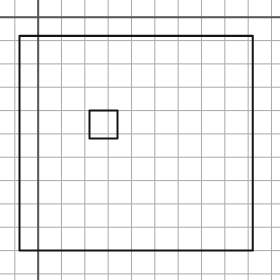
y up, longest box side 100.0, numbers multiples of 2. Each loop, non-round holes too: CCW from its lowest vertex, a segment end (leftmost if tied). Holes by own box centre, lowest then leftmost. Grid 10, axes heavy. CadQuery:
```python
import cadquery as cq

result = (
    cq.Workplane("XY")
    .moveTo(-8.0, -100.0)
    .lineTo(92.0, -100.0)
    .lineTo(92.0, -8.0)
    .lineTo(-8.0, -8.0)
    .close()
    .moveTo(22.0, -52.0)
    .lineTo(34.0, -52.0)
    .lineTo(34.0, -40.0)
    .lineTo(22.0, -40.0)
    .close()
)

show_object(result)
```